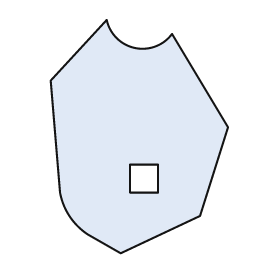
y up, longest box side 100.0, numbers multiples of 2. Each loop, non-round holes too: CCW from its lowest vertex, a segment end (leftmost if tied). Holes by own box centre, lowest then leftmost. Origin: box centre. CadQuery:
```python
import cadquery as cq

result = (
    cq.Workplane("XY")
    .moveTo(-8.0, -50.0)
    .lineTo(26.0, -34.0)
    .lineTo(38.0, 4.0)
    .lineTo(14.0, 44.0)
    .threePointArc((-2.0, 38.0), (-14.0, 50.0))
    .lineTo(-38.0, 24.0)
    .lineTo(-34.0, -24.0)
    .threePointArc((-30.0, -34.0), (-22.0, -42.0))
    .close()
    .moveTo(-4.0, -24.0)
    .lineTo(8.0, -24.0)
    .lineTo(8.0, -12.0)
    .lineTo(-4.0, -12.0)
    .close()
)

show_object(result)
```